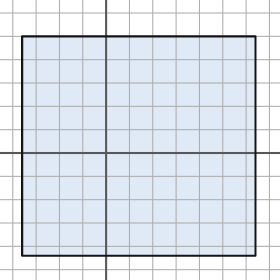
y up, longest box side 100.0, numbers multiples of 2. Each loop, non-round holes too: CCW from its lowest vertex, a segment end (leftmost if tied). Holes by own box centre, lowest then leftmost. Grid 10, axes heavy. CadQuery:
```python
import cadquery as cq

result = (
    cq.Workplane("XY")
    .moveTo(-36.0, -44.0)
    .lineTo(64.0, -44.0)
    .lineTo(64.0, 50.0)
    .lineTo(-36.0, 50.0)
    .close()
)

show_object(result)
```